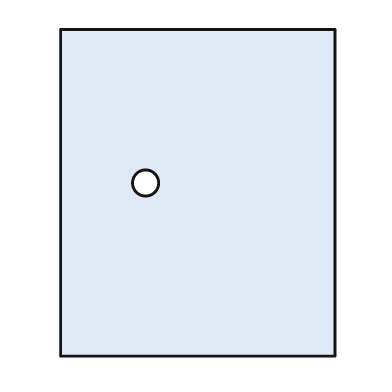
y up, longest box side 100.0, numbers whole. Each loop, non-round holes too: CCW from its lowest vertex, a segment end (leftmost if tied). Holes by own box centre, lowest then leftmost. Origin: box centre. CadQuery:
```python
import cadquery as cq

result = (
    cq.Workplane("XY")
    .moveTo(-42.0, -50.0)
    .lineTo(42.0, -50.0)
    .lineTo(42.0, 50.0)
    .lineTo(-42.0, 50.0)
    .close()
    .moveTo(-16.0, 3.0)
    .circle(4.0)
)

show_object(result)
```